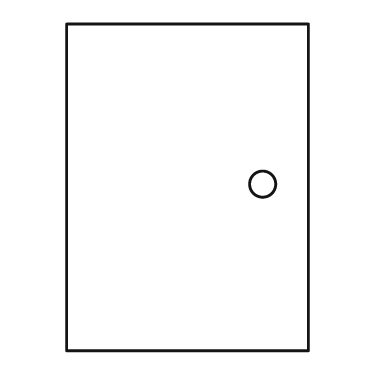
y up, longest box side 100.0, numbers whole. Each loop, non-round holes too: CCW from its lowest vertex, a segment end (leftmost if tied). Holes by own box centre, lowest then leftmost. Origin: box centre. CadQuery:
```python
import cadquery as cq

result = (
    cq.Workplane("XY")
    .moveTo(-37.0, -50.0)
    .lineTo(37.0, -50.0)
    .lineTo(37.0, 50.0)
    .lineTo(-37.0, 50.0)
    .close()
    .moveTo(23.0, 1.0)
    .circle(4.0)
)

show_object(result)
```